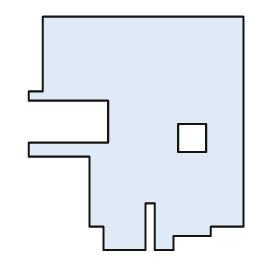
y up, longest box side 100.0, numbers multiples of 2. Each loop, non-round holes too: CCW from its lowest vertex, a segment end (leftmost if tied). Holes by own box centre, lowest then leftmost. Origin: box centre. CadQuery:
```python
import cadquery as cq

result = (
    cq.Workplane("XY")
    .moveTo(-14.0, -50.0)
    .lineTo(4.0, -50.0)
    .lineTo(4.0, -30.0)
    .lineTo(8.0, -30.0)
    .lineTo(8.0, -50.0)
    .lineTo(16.0, -50.0)
    .lineTo(16.0, -44.0)
    .lineTo(32.0, -44.0)
    .lineTo(32.0, -40.0)
    .lineTo(46.0, -40.0)
    .lineTo(46.0, 50.0)
    .lineTo(-40.0, 50.0)
    .lineTo(-40.0, 18.0)
    .lineTo(-46.0, 18.0)
    .lineTo(-46.0, 14.0)
    .lineTo(-12.0, 14.0)
    .lineTo(-12.0, -4.0)
    .lineTo(-46.0, -4.0)
    .lineTo(-46.0, -10.0)
    .lineTo(-20.0, -10.0)
    .lineTo(-20.0, -40.0)
    .lineTo(-14.0, -40.0)
    .close()
    .moveTo(18.0, -8.0)
    .lineTo(30.0, -8.0)
    .lineTo(30.0, 4.0)
    .lineTo(18.0, 4.0)
    .close()
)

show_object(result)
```